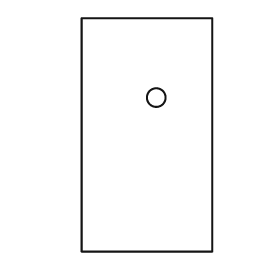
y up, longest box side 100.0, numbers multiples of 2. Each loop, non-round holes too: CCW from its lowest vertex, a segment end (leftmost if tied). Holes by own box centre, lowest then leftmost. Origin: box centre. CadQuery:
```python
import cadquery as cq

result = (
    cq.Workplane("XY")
    .moveTo(-28.0, -50.0)
    .lineTo(28.0, -50.0)
    .lineTo(28.0, 50.0)
    .lineTo(-28.0, 50.0)
    .close()
    .moveTo(4.0, 16.0)
    .circle(4.0)
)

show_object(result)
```